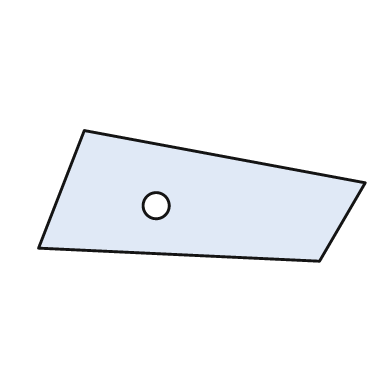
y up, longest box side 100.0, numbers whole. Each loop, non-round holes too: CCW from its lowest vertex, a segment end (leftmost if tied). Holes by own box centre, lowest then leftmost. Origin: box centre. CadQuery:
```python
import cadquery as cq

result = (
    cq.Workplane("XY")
    .moveTo(36.0, -20.0)
    .lineTo(50.0, 4.0)
    .lineTo(-36.0, 20.0)
    .lineTo(-50.0, -16.0)
    .close()
    .moveTo(-14.0, -3.0)
    .circle(4.0)
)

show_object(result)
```